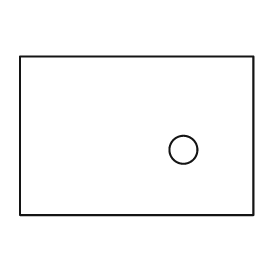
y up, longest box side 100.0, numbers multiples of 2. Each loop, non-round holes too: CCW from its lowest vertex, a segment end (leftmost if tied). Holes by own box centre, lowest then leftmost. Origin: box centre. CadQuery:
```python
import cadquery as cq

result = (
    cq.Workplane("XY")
    .moveTo(-50.0, -34.0)
    .lineTo(50.0, -34.0)
    .lineTo(50.0, 34.0)
    .lineTo(-50.0, 34.0)
    .close()
    .moveTo(20.0, -6.0)
    .circle(6.0)
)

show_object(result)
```